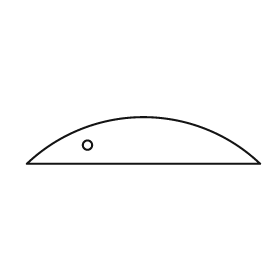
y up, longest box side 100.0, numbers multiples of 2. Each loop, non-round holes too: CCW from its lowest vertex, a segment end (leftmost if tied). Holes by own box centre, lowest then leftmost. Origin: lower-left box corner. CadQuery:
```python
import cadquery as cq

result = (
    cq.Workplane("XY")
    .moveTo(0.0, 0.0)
    .lineTo(100.0, 0.0)
    .threePointArc((50.0, 20.0), (0.0, 0.0))
    .close()
    .moveTo(26.0, 8.0)
    .circle(2.0)
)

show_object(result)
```